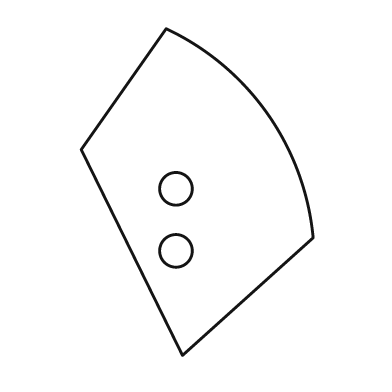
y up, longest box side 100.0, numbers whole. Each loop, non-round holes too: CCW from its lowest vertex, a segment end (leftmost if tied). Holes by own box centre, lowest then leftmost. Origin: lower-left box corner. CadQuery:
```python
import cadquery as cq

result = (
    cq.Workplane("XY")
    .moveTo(31.0, 0.0)
    .lineTo(71.0, 36.0)
    .threePointArc((57.0, 74.0), (26.0, 100.0))
    .lineTo(0.0, 63.0)
    .close()
    .moveTo(29.0, 32.0)
    .circle(5.0)
    .moveTo(29.0, 51.0)
    .circle(5.0)
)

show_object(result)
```